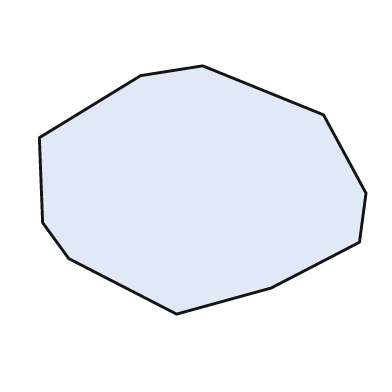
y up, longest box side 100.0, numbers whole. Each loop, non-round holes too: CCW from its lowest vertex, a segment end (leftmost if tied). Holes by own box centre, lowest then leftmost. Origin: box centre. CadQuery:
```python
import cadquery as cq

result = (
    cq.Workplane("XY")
    .moveTo(-8.0, -38.0)
    .lineTo(21.0, -30.0)
    .lineTo(48.0, -16.0)
    .lineTo(50.0, -1.0)
    .lineTo(37.0, 23.0)
    .lineTo(0.0, 38.0)
    .lineTo(-19.0, 35.0)
    .lineTo(-50.0, 16.0)
    .lineTo(-49.0, -10.0)
    .lineTo(-41.0, -21.0)
    .close()
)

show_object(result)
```